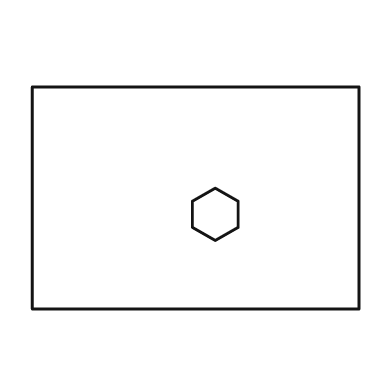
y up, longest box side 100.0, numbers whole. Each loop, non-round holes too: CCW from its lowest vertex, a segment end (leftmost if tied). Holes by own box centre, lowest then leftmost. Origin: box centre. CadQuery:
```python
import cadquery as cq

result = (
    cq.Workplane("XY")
    .moveTo(-50.0, -34.0)
    .lineTo(50.0, -34.0)
    .lineTo(50.0, 34.0)
    .lineTo(-50.0, 34.0)
    .close()
    .moveTo(6.0, -13.0)
    .lineTo(13.0, -9.0)
    .lineTo(13.0, -1.0)
    .lineTo(6.0, 3.0)
    .lineTo(-1.0, -1.0)
    .lineTo(-1.0, -9.0)
    .close()
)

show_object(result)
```